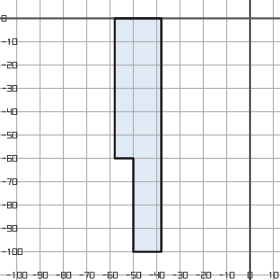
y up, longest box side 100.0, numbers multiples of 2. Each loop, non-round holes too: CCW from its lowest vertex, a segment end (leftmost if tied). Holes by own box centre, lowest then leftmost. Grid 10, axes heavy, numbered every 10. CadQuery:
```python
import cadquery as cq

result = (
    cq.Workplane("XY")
    .moveTo(-50.0, -100.0)
    .lineTo(-38.0, -100.0)
    .lineTo(-38.0, 0.0)
    .lineTo(-58.0, 0.0)
    .lineTo(-58.0, -60.0)
    .lineTo(-50.0, -60.0)
    .close()
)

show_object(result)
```